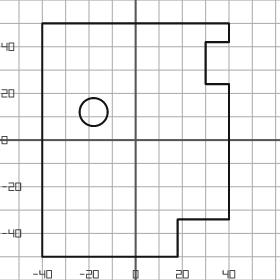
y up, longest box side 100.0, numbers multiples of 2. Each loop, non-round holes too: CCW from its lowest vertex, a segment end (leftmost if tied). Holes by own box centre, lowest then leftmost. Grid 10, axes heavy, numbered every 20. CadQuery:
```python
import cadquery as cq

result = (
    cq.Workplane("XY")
    .moveTo(-40.0, -50.0)
    .lineTo(18.0, -50.0)
    .lineTo(18.0, -34.0)
    .lineTo(40.0, -34.0)
    .lineTo(40.0, 24.0)
    .lineTo(30.0, 24.0)
    .lineTo(30.0, 42.0)
    .lineTo(40.0, 42.0)
    .lineTo(40.0, 50.0)
    .lineTo(-40.0, 50.0)
    .close()
    .moveTo(-18.0, 12.0)
    .circle(6.0)
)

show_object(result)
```